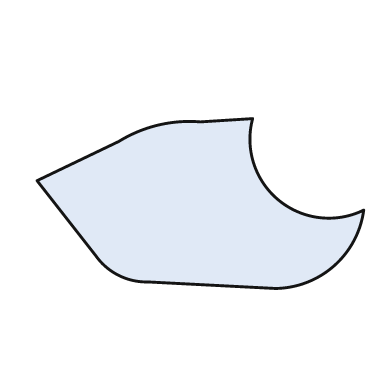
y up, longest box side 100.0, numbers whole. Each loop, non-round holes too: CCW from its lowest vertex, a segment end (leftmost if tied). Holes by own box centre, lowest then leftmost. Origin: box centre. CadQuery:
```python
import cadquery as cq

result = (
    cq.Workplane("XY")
    .moveTo(23.0, -26.0)
    .threePointArc((41.0, -19.0), (50.0, -2.0))
    .threePointArc((24.0, 1.0), (16.0, 26.0))
    .lineTo(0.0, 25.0)
    .threePointArc((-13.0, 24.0), (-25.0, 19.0))
    .lineTo(-50.0, 7.0)
    .lineTo(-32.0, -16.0)
    .threePointArc((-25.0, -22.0), (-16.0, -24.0))
    .close()
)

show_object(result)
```